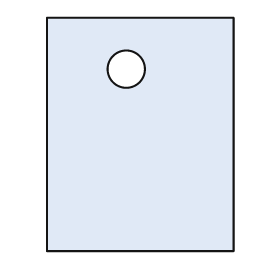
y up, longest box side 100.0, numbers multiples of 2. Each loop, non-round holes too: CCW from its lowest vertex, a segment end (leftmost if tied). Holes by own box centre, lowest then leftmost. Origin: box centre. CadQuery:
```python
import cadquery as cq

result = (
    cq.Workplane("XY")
    .moveTo(-40.0, -50.0)
    .lineTo(40.0, -50.0)
    .lineTo(40.0, 50.0)
    .lineTo(-40.0, 50.0)
    .close()
    .moveTo(-6.0, 28.0)
    .circle(8.0)
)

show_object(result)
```